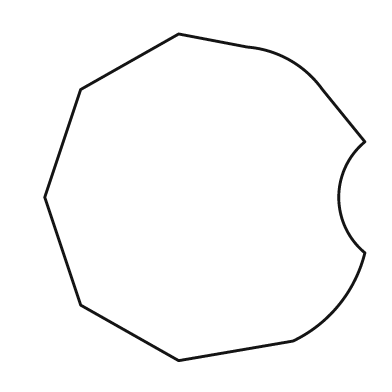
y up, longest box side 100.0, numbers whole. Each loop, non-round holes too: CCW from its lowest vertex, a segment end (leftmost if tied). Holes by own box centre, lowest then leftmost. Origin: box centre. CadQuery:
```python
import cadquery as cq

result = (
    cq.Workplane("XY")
    .moveTo(-8.0, -50.0)
    .lineTo(27.0, -44.0)
    .threePointArc((41.0, -33.0), (49.0, -17.0))
    .threePointArc((41.0, 0.0), (49.0, 17.0))
    .lineTo(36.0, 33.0)
    .threePointArc((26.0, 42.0), (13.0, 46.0))
    .lineTo(-8.0, 50.0)
    .lineTo(-38.0, 33.0)
    .lineTo(-49.0, 0.0)
    .lineTo(-38.0, -33.0)
    .close()
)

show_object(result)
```